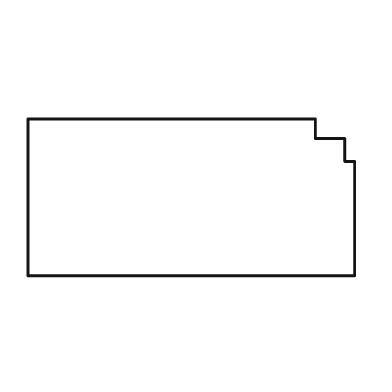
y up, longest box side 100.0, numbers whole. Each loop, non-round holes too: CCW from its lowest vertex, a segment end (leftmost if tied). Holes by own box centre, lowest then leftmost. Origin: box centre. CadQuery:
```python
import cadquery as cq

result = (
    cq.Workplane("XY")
    .moveTo(-50.0, -24.0)
    .lineTo(50.0, -24.0)
    .lineTo(50.0, 11.0)
    .lineTo(47.0, 11.0)
    .lineTo(47.0, 18.0)
    .lineTo(38.0, 18.0)
    .lineTo(38.0, 24.0)
    .lineTo(-50.0, 24.0)
    .close()
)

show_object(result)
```